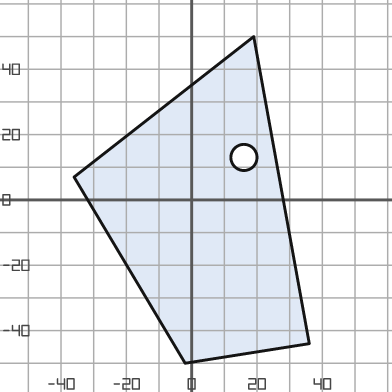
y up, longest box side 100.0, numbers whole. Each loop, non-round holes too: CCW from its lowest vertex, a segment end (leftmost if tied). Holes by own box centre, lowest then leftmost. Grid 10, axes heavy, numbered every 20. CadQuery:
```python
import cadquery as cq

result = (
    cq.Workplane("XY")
    .moveTo(-2.0, -50.0)
    .lineTo(36.0, -44.0)
    .lineTo(19.0, 50.0)
    .lineTo(-36.0, 7.0)
    .close()
    .moveTo(16.0, 13.0)
    .circle(4.0)
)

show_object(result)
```